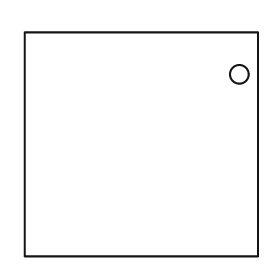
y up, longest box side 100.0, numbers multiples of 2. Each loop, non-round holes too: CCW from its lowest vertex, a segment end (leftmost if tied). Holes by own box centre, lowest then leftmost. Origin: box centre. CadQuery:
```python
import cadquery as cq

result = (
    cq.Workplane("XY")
    .moveTo(-50.0, -48.0)
    .lineTo(50.0, -48.0)
    .lineTo(50.0, 48.0)
    .lineTo(-50.0, 48.0)
    .close()
    .moveTo(42.0, 30.0)
    .circle(4.0)
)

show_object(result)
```